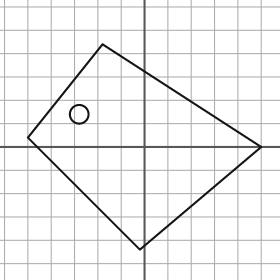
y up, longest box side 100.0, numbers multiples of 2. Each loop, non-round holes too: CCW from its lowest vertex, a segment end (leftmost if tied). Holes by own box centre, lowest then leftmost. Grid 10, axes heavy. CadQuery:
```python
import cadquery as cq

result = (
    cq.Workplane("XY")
    .moveTo(-2.0, -44.0)
    .lineTo(50.0, 0.0)
    .lineTo(-18.0, 44.0)
    .lineTo(-50.0, 4.0)
    .close()
    .moveTo(-28.0, 14.0)
    .circle(4.0)
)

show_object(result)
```